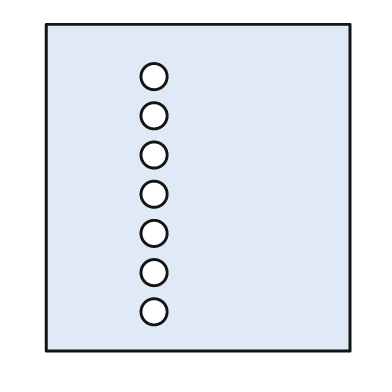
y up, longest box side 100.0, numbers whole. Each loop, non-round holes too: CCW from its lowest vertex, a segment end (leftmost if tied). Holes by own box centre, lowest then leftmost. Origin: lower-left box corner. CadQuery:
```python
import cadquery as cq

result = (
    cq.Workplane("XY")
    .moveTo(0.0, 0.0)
    .lineTo(93.0, 0.0)
    .lineTo(93.0, 100.0)
    .lineTo(0.0, 100.0)
    .close()
    .moveTo(33.0, 12.0)
    .circle(4.0)
    .moveTo(33.0, 24.0)
    .circle(4.0)
    .moveTo(33.0, 36.0)
    .circle(4.0)
    .moveTo(33.0, 48.0)
    .circle(4.0)
    .moveTo(33.0, 60.0)
    .circle(4.0)
    .moveTo(33.0, 72.0)
    .circle(4.0)
    .moveTo(33.0, 84.0)
    .circle(4.0)
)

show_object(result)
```